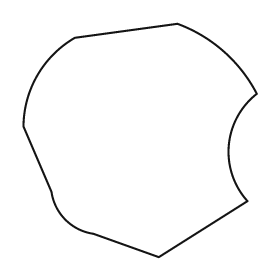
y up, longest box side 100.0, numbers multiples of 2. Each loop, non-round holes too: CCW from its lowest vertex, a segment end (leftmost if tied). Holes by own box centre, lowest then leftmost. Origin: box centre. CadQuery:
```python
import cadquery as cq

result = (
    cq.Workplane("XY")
    .moveTo(8.0, -50.0)
    .lineTo(46.0, -26.0)
    .threePointArc((38.0, -2.0), (50.0, 20.0))
    .threePointArc((36.0, 38.0), (16.0, 50.0))
    .lineTo(-28.0, 44.0)
    .threePointArc((-44.0, 28.0), (-50.0, 6.0))
    .lineTo(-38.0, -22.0)
    .threePointArc((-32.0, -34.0), (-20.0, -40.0))
    .close()
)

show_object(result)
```